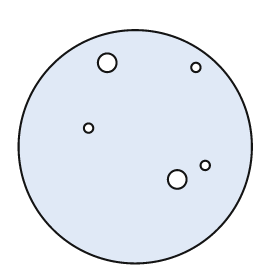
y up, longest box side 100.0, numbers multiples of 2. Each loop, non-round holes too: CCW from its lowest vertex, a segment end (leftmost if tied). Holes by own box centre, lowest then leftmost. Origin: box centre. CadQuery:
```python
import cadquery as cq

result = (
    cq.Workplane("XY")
    .moveTo(0.0, 0.0)
    .circle(50.0)
    .moveTo(18.0, -14.0)
    .circle(4.0)
    .moveTo(30.0, -8.0)
    .circle(2.0)
    .moveTo(-20.0, 8.0)
    .circle(2.0)
    .moveTo(26.0, 34.0)
    .circle(2.0)
    .moveTo(-12.0, 36.0)
    .circle(4.0)
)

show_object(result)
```